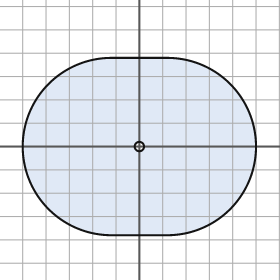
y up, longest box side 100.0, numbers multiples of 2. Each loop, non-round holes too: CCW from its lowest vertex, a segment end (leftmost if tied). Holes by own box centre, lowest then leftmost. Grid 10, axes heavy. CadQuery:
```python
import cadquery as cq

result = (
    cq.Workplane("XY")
    .moveTo(-12.0, -38.0)
    .lineTo(12.0, -38.0)
    .threePointArc((50.0, 0.0), (12.0, 38.0))
    .lineTo(-12.0, 38.0)
    .threePointArc((-50.0, 0.0), (-12.0, -38.0))
    .close()
    .moveTo(0.0, 0.0)
    .circle(2.0)
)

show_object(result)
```